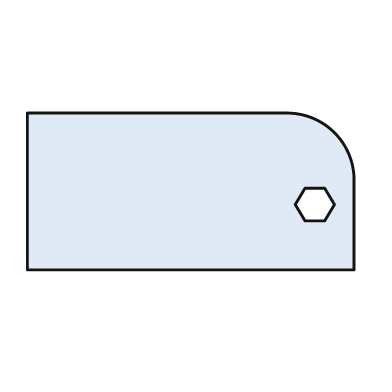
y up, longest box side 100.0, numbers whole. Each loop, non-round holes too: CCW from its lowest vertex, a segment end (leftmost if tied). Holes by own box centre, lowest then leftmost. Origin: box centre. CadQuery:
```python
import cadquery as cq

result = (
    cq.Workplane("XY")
    .moveTo(-50.0, -24.0)
    .lineTo(50.0, -24.0)
    .lineTo(50.0, 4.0)
    .threePointArc((44.0, 18.0), (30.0, 24.0))
    .lineTo(-50.0, 24.0)
    .close()
    .moveTo(35.0, -9.0)
    .lineTo(41.0, -9.0)
    .lineTo(44.0, -4.0)
    .lineTo(41.0, 1.0)
    .lineTo(35.0, 1.0)
    .lineTo(32.0, -4.0)
    .close()
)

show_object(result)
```